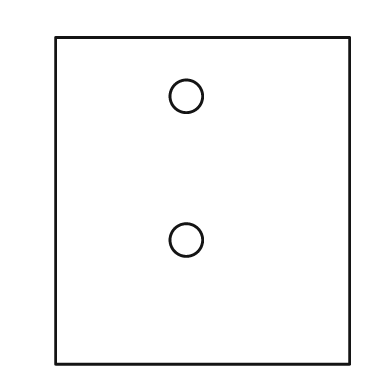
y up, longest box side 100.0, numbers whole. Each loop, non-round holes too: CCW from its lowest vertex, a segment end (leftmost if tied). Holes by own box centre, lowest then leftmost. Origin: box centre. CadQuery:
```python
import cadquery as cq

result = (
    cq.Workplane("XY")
    .moveTo(-45.0, -50.0)
    .lineTo(45.0, -50.0)
    .lineTo(45.0, 50.0)
    .lineTo(-45.0, 50.0)
    .close()
    .moveTo(-5.0, -12.0)
    .circle(5.0)
    .moveTo(-5.0, 32.0)
    .circle(5.0)
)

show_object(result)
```